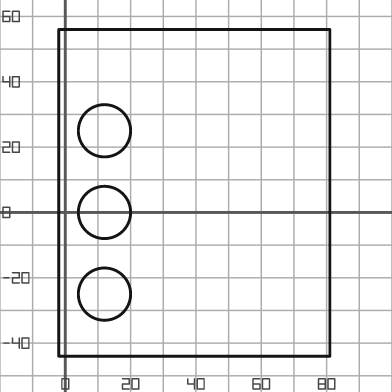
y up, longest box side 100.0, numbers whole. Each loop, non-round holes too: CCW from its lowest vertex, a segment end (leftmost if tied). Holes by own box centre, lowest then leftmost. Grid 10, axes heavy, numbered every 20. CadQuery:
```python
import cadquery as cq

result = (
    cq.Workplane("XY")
    .moveTo(-2.0, -44.0)
    .lineTo(81.0, -44.0)
    .lineTo(81.0, 56.0)
    .lineTo(-2.0, 56.0)
    .close()
    .moveTo(12.0, -25.0)
    .circle(8.0)
    .moveTo(12.0, 0.0)
    .circle(8.0)
    .moveTo(12.0, 25.0)
    .circle(8.0)
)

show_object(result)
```